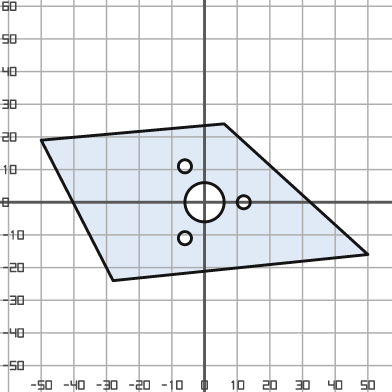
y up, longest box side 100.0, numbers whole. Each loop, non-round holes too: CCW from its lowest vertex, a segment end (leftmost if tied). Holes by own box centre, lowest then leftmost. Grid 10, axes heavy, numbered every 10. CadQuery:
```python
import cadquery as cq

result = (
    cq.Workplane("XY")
    .moveTo(-28.0, -24.0)
    .lineTo(50.0, -16.0)
    .lineTo(6.0, 24.0)
    .lineTo(-50.0, 19.0)
    .close()
    .moveTo(-6.0, -11.0)
    .circle(2.0)
    .moveTo(0.0, 0.0)
    .circle(6.0)
    .moveTo(12.0, 0.0)
    .circle(2.0)
    .moveTo(-6.0, 11.0)
    .circle(2.0)
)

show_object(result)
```